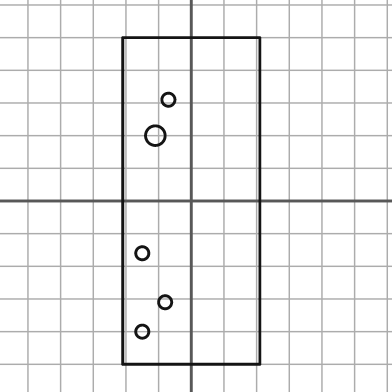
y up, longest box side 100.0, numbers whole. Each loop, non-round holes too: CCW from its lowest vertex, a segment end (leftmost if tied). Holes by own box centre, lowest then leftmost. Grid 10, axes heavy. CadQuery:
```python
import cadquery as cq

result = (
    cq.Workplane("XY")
    .moveTo(-21.0, -50.0)
    .lineTo(21.0, -50.0)
    .lineTo(21.0, 50.0)
    .lineTo(-21.0, 50.0)
    .close()
    .moveTo(-15.0, -40.0)
    .circle(2.0)
    .moveTo(-8.0, -31.0)
    .circle(2.0)
    .moveTo(-15.0, -16.0)
    .circle(2.0)
    .moveTo(-11.0, 20.0)
    .circle(3.0)
    .moveTo(-7.0, 31.0)
    .circle(2.0)
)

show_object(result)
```